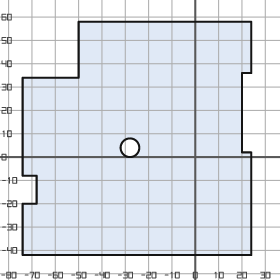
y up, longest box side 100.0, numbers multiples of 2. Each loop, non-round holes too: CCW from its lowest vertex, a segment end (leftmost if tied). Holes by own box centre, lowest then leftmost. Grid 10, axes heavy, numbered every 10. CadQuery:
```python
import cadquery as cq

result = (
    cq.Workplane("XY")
    .moveTo(-74.0, -42.0)
    .lineTo(24.0, -42.0)
    .lineTo(24.0, 2.0)
    .lineTo(20.0, 2.0)
    .lineTo(20.0, 36.0)
    .lineTo(24.0, 36.0)
    .lineTo(24.0, 58.0)
    .lineTo(-50.0, 58.0)
    .lineTo(-50.0, 34.0)
    .lineTo(-74.0, 34.0)
    .lineTo(-74.0, -8.0)
    .lineTo(-68.0, -8.0)
    .lineTo(-68.0, -20.0)
    .lineTo(-74.0, -20.0)
    .close()
    .moveTo(-28.0, 4.0)
    .circle(4.0)
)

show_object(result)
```